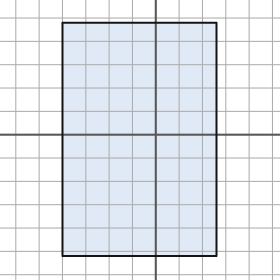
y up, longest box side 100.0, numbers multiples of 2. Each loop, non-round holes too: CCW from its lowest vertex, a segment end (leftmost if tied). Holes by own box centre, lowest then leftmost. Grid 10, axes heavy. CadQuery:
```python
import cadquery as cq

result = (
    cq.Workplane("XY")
    .moveTo(-40.0, -52.0)
    .lineTo(26.0, -52.0)
    .lineTo(26.0, 48.0)
    .lineTo(-40.0, 48.0)
    .close()
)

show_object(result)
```